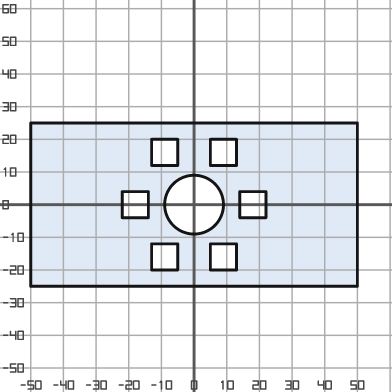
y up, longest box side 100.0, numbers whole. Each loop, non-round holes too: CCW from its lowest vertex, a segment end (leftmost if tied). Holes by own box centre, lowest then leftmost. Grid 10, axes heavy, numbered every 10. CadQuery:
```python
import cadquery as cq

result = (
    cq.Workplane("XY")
    .moveTo(-50.0, -25.0)
    .lineTo(50.0, -25.0)
    .lineTo(50.0, 25.0)
    .lineTo(-50.0, 25.0)
    .close()
    .moveTo(-13.0, -20.0)
    .lineTo(-5.0, -20.0)
    .lineTo(-5.0, -12.0)
    .lineTo(-13.0, -12.0)
    .close()
    .moveTo(5.0, -20.0)
    .lineTo(13.0, -20.0)
    .lineTo(13.0, -12.0)
    .lineTo(5.0, -12.0)
    .close()
    .moveTo(-22.0, -4.0)
    .lineTo(-14.0, -4.0)
    .lineTo(-14.0, 4.0)
    .lineTo(-22.0, 4.0)
    .close()
    .moveTo(0.0, 0.0)
    .circle(9.0)
    .moveTo(14.0, -4.0)
    .lineTo(22.0, -4.0)
    .lineTo(22.0, 4.0)
    .lineTo(14.0, 4.0)
    .close()
    .moveTo(-13.0, 12.0)
    .lineTo(-5.0, 12.0)
    .lineTo(-5.0, 20.0)
    .lineTo(-13.0, 20.0)
    .close()
    .moveTo(5.0, 12.0)
    .lineTo(13.0, 12.0)
    .lineTo(13.0, 20.0)
    .lineTo(5.0, 20.0)
    .close()
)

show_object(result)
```